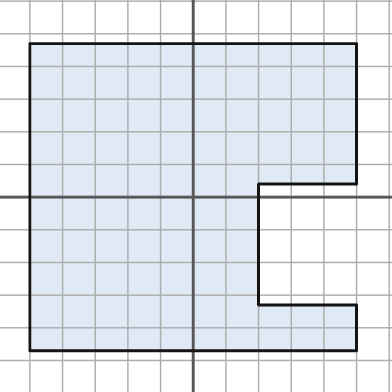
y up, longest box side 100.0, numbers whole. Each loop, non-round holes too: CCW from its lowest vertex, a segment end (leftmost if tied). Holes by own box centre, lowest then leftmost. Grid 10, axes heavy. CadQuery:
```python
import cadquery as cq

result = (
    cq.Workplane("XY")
    .moveTo(-50.0, -47.0)
    .lineTo(50.0, -47.0)
    .lineTo(50.0, -33.0)
    .lineTo(20.0, -33.0)
    .lineTo(20.0, 4.0)
    .lineTo(50.0, 4.0)
    .lineTo(50.0, 47.0)
    .lineTo(-50.0, 47.0)
    .close()
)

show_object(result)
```